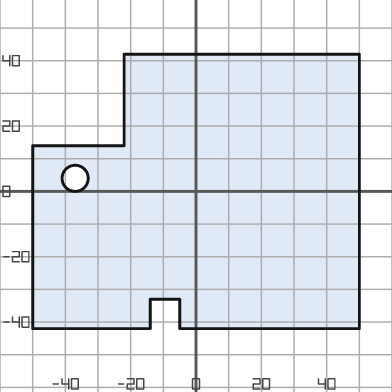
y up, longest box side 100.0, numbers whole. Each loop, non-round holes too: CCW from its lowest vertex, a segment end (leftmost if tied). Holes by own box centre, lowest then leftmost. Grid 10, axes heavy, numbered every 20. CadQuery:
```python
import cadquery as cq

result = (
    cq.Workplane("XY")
    .moveTo(-50.0, -42.0)
    .lineTo(-14.0, -42.0)
    .lineTo(-14.0, -33.0)
    .lineTo(-5.0, -33.0)
    .lineTo(-5.0, -42.0)
    .lineTo(50.0, -42.0)
    .lineTo(50.0, 42.0)
    .lineTo(-22.0, 42.0)
    .lineTo(-22.0, 14.0)
    .lineTo(-50.0, 14.0)
    .close()
    .moveTo(-37.0, 4.0)
    .circle(4.0)
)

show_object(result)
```